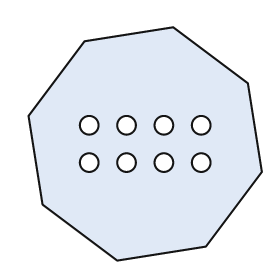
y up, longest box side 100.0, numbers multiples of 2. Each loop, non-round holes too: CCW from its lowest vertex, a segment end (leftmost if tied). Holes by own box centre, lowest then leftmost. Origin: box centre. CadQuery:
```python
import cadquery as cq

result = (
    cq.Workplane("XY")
    .moveTo(-12.0, -50.0)
    .lineTo(26.0, -44.0)
    .lineTo(50.0, -12.0)
    .lineTo(44.0, 26.0)
    .lineTo(12.0, 50.0)
    .lineTo(-26.0, 44.0)
    .lineTo(-50.0, 12.0)
    .lineTo(-44.0, -26.0)
    .close()
    .moveTo(-24.0, -8.0)
    .circle(4.0)
    .moveTo(-8.0, -8.0)
    .circle(4.0)
    .moveTo(8.0, -8.0)
    .circle(4.0)
    .moveTo(24.0, -8.0)
    .circle(4.0)
    .moveTo(-24.0, 8.0)
    .circle(4.0)
    .moveTo(-8.0, 8.0)
    .circle(4.0)
    .moveTo(8.0, 8.0)
    .circle(4.0)
    .moveTo(24.0, 8.0)
    .circle(4.0)
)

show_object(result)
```